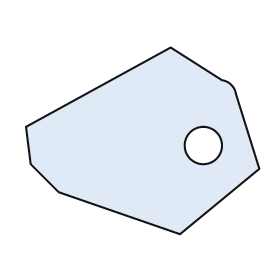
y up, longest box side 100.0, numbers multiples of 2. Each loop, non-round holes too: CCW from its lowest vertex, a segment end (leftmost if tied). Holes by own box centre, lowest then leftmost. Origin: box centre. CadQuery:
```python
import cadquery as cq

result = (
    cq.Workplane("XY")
    .moveTo(16.0, -40.0)
    .lineTo(50.0, -12.0)
    .lineTo(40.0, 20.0)
    .threePointArc((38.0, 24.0), (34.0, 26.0))
    .lineTo(12.0, 40.0)
    .lineTo(-50.0, 6.0)
    .lineTo(-48.0, -10.0)
    .lineTo(-36.0, -22.0)
    .close()
    .moveTo(26.0, -2.0)
    .circle(8.0)
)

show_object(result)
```